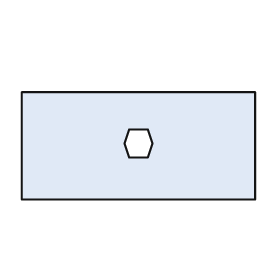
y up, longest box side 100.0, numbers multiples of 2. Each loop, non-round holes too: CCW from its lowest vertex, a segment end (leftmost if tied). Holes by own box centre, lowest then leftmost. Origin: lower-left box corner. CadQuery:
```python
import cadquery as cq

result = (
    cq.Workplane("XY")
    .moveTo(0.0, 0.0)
    .lineTo(100.0, 0.0)
    .lineTo(100.0, 46.0)
    .lineTo(0.0, 46.0)
    .close()
    .moveTo(46.0, 18.0)
    .lineTo(54.0, 18.0)
    .lineTo(56.0, 24.0)
    .lineTo(54.0, 30.0)
    .lineTo(46.0, 30.0)
    .lineTo(44.0, 24.0)
    .close()
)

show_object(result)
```